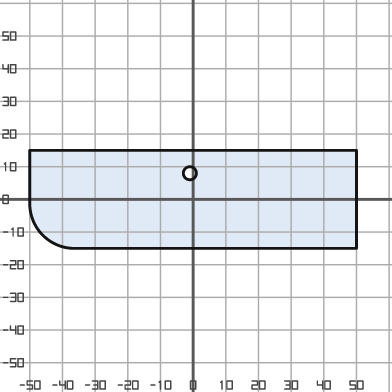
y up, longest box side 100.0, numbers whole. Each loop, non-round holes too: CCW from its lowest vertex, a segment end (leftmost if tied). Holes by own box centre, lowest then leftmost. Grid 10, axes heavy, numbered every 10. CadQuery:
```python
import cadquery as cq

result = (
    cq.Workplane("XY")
    .moveTo(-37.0, -15.0)
    .lineTo(50.0, -15.0)
    .lineTo(50.0, 15.0)
    .lineTo(-50.0, 15.0)
    .lineTo(-50.0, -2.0)
    .threePointArc((-46.0, -11.0), (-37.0, -15.0))
    .close()
    .moveTo(-1.0, 8.0)
    .circle(2.0)
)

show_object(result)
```